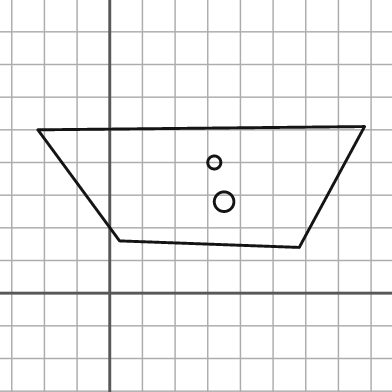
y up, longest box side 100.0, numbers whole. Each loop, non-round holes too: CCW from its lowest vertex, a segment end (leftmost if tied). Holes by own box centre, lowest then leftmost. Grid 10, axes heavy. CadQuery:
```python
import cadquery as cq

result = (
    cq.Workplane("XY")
    .moveTo(58.0, 14.0)
    .lineTo(78.0, 51.0)
    .lineTo(-22.0, 50.0)
    .lineTo(3.0, 16.0)
    .close()
    .moveTo(35.0, 28.0)
    .circle(3.0)
    .moveTo(32.0, 40.0)
    .circle(2.0)
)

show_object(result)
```